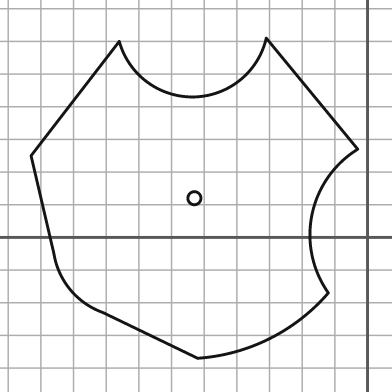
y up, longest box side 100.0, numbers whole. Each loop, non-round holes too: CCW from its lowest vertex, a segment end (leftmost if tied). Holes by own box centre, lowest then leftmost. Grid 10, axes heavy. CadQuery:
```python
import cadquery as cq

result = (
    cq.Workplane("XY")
    .moveTo(-52.0, -37.0)
    .threePointArc((-30.0, -31.0), (-12.0, -17.0))
    .threePointArc((-17.0, 7.0), (-3.0, 27.0))
    .lineTo(-31.0, 61.0)
    .threePointArc((-53.0, 43.0), (-76.0, 60.0))
    .lineTo(-103.0, 25.0)
    .lineTo(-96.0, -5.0)
    .threePointArc((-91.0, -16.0), (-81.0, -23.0))
    .close()
    .moveTo(-53.0, 12.0)
    .circle(2.0)
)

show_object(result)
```